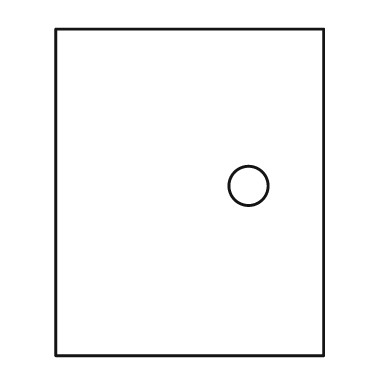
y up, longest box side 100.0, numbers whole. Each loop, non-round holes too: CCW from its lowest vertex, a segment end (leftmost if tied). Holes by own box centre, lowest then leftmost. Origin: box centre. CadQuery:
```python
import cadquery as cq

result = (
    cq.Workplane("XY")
    .moveTo(-41.0, -50.0)
    .lineTo(41.0, -50.0)
    .lineTo(41.0, 50.0)
    .lineTo(-41.0, 50.0)
    .close()
    .moveTo(18.0, 2.0)
    .circle(6.0)
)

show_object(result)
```